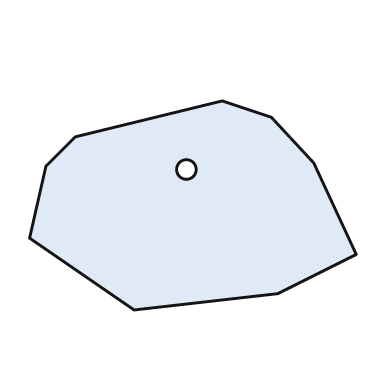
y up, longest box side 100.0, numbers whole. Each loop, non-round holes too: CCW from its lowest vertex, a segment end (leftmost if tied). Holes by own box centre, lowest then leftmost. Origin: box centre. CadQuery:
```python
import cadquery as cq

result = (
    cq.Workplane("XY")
    .moveTo(-18.0, -32.0)
    .lineTo(26.0, -27.0)
    .lineTo(50.0, -15.0)
    .lineTo(37.0, 13.0)
    .lineTo(24.0, 27.0)
    .lineTo(9.0, 32.0)
    .lineTo(-36.0, 21.0)
    .lineTo(-45.0, 12.0)
    .lineTo(-50.0, -10.0)
    .close()
    .moveTo(-2.0, 11.0)
    .circle(3.0)
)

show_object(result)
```